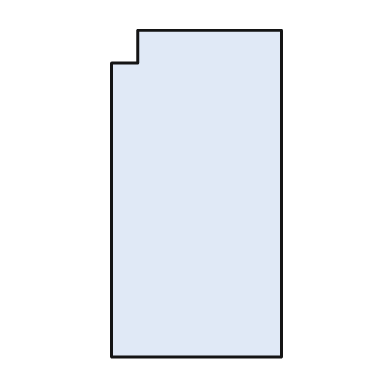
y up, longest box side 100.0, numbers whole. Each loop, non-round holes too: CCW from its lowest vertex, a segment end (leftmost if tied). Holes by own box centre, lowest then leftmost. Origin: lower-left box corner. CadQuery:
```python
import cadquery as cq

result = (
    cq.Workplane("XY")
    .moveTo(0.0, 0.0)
    .lineTo(52.0, 0.0)
    .lineTo(52.0, 100.0)
    .lineTo(8.0, 100.0)
    .lineTo(8.0, 90.0)
    .lineTo(0.0, 90.0)
    .close()
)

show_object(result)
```